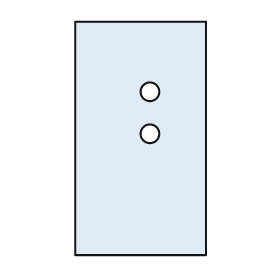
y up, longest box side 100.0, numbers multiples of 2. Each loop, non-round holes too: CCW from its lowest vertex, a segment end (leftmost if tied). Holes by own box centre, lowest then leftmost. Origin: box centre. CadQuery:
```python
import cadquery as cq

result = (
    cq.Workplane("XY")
    .moveTo(-28.0, -50.0)
    .lineTo(28.0, -50.0)
    .lineTo(28.0, 50.0)
    .lineTo(-28.0, 50.0)
    .close()
    .moveTo(4.0, 2.0)
    .circle(4.0)
    .moveTo(4.0, 20.0)
    .circle(4.0)
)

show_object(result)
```